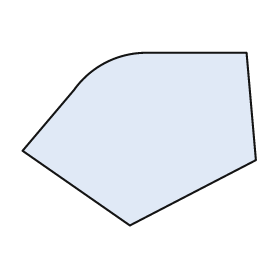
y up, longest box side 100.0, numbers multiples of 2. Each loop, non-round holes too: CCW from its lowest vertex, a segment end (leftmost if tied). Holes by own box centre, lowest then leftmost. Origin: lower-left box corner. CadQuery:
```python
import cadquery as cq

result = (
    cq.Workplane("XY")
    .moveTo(46.0, 0.0)
    .lineTo(100.0, 28.0)
    .lineTo(96.0, 74.0)
    .lineTo(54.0, 74.0)
    .threePointArc((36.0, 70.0), (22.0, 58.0))
    .lineTo(0.0, 32.0)
    .close()
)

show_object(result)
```